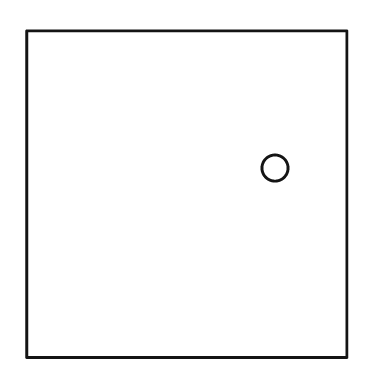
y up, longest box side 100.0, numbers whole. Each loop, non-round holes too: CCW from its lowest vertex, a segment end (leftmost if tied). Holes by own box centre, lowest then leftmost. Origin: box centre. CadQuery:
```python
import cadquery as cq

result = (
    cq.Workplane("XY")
    .moveTo(-49.0, -50.0)
    .lineTo(49.0, -50.0)
    .lineTo(49.0, 50.0)
    .lineTo(-49.0, 50.0)
    .close()
    .moveTo(27.0, 8.0)
    .circle(4.0)
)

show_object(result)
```